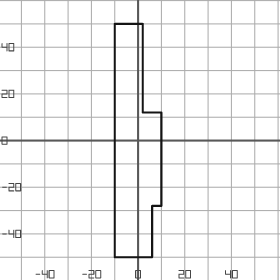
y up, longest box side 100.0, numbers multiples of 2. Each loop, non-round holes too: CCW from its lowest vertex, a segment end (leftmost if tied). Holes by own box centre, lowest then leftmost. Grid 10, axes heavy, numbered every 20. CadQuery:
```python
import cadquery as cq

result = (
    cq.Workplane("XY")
    .moveTo(-10.0, -50.0)
    .lineTo(6.0, -50.0)
    .lineTo(6.0, -28.0)
    .lineTo(10.0, -28.0)
    .lineTo(10.0, 12.0)
    .lineTo(2.0, 12.0)
    .lineTo(2.0, 50.0)
    .lineTo(-10.0, 50.0)
    .close()
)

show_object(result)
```